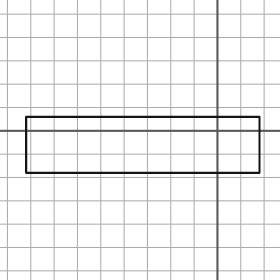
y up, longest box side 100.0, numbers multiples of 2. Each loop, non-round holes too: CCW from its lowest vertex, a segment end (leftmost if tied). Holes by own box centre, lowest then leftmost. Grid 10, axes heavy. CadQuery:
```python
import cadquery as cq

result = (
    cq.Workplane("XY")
    .moveTo(-82.0, -18.0)
    .lineTo(18.0, -18.0)
    .lineTo(18.0, 6.0)
    .lineTo(-82.0, 6.0)
    .close()
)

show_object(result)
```